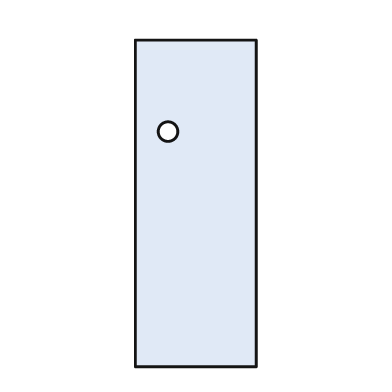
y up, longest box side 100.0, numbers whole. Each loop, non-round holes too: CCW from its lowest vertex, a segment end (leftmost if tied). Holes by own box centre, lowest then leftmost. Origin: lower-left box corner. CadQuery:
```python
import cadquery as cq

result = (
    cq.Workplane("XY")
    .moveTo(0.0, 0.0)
    .lineTo(37.0, 0.0)
    .lineTo(37.0, 100.0)
    .lineTo(0.0, 100.0)
    .close()
    .moveTo(10.0, 72.0)
    .circle(3.0)
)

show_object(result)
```